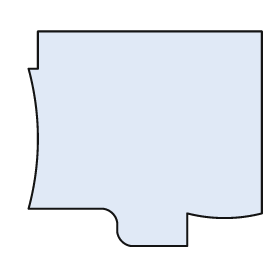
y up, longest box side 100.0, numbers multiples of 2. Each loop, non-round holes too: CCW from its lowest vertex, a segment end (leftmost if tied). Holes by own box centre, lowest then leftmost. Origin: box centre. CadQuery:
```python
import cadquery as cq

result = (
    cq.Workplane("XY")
    .moveTo(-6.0, -46.0)
    .lineTo(18.0, -46.0)
    .lineTo(18.0, -32.0)
    .threePointArc((34.0, -34.0), (50.0, -32.0))
    .lineTo(50.0, 46.0)
    .lineTo(-46.0, 46.0)
    .lineTo(-46.0, 30.0)
    .lineTo(-50.0, 30.0)
    .threePointArc((-46.0, 0.0), (-50.0, -30.0))
    .lineTo(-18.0, -30.0)
    .threePointArc((-14.0, -32.0), (-12.0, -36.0))
    .lineTo(-12.0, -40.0)
    .threePointArc((-10.0, -44.0), (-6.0, -46.0))
    .close()
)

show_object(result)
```